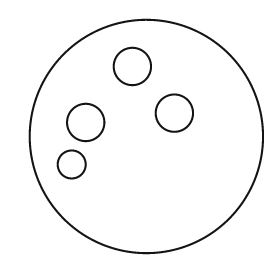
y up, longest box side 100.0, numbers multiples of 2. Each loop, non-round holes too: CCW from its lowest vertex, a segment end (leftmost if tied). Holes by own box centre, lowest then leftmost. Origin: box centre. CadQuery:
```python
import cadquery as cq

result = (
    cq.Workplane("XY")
    .moveTo(0.0, 0.0)
    .circle(50.0)
    .moveTo(-32.0, -12.0)
    .circle(6.0)
    .moveTo(-26.0, 6.0)
    .circle(8.0)
    .moveTo(12.0, 10.0)
    .circle(8.0)
    .moveTo(-6.0, 30.0)
    .circle(8.0)
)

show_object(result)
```